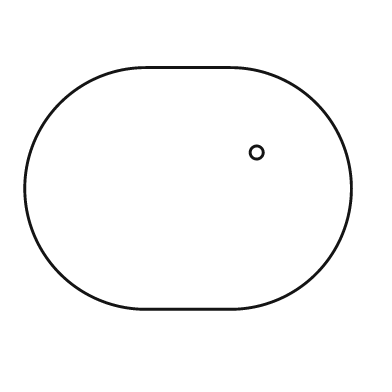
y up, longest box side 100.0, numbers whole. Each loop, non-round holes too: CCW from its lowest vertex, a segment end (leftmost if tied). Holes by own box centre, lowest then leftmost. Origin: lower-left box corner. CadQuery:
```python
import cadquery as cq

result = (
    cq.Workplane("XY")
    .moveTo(37.0, 0.0)
    .lineTo(63.0, 0.0)
    .threePointArc((100.0, 37.0), (63.0, 74.0))
    .lineTo(37.0, 74.0)
    .threePointArc((0.0, 37.0), (37.0, 0.0))
    .close()
    .moveTo(71.0, 48.0)
    .circle(2.0)
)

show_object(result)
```